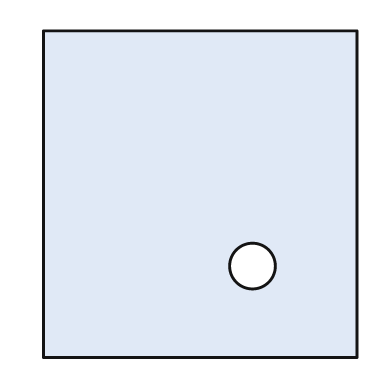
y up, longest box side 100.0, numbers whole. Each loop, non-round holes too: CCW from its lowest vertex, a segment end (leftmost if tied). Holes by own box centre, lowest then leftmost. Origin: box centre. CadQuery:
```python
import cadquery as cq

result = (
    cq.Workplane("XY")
    .moveTo(-48.0, -50.0)
    .lineTo(48.0, -50.0)
    .lineTo(48.0, 50.0)
    .lineTo(-48.0, 50.0)
    .close()
    .moveTo(16.0, -22.0)
    .circle(7.0)
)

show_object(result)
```